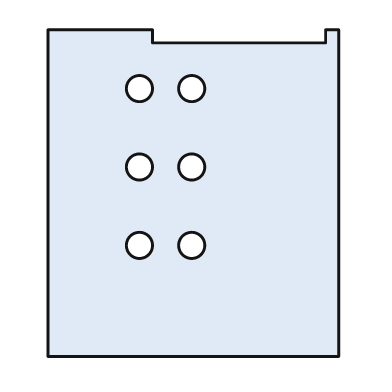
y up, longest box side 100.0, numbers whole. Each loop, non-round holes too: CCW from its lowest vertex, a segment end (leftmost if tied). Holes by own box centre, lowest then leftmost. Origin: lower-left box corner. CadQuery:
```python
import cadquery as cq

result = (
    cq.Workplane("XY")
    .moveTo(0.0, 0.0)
    .lineTo(89.0, 0.0)
    .lineTo(89.0, 100.0)
    .lineTo(85.0, 100.0)
    .lineTo(85.0, 96.0)
    .lineTo(32.0, 96.0)
    .lineTo(32.0, 100.0)
    .lineTo(0.0, 100.0)
    .close()
    .moveTo(28.0, 34.0)
    .circle(4.0)
    .moveTo(44.0, 34.0)
    .circle(4.0)
    .moveTo(28.0, 58.0)
    .circle(4.0)
    .moveTo(44.0, 58.0)
    .circle(4.0)
    .moveTo(28.0, 82.0)
    .circle(4.0)
    .moveTo(44.0, 82.0)
    .circle(4.0)
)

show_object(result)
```